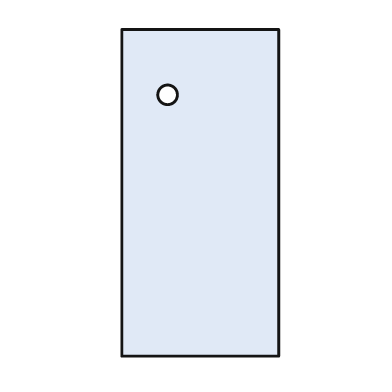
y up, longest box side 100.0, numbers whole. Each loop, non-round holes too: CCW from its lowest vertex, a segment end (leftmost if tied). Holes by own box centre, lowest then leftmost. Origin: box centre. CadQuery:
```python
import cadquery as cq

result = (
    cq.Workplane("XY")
    .moveTo(-24.0, -50.0)
    .lineTo(24.0, -50.0)
    .lineTo(24.0, 50.0)
    .lineTo(-24.0, 50.0)
    .close()
    .moveTo(-10.0, 30.0)
    .circle(3.0)
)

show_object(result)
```